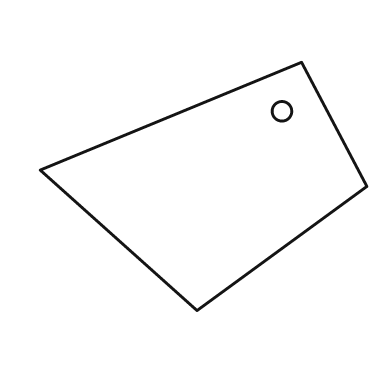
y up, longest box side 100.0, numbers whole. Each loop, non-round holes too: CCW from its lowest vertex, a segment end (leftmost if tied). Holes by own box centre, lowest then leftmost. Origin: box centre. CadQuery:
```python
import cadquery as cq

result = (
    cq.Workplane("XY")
    .moveTo(-2.0, -38.0)
    .lineTo(50.0, 0.0)
    .lineTo(30.0, 38.0)
    .lineTo(-50.0, 5.0)
    .close()
    .moveTo(24.0, 23.0)
    .circle(3.0)
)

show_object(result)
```